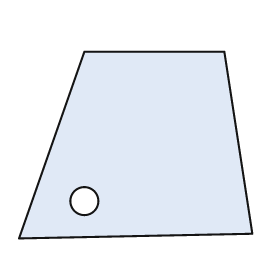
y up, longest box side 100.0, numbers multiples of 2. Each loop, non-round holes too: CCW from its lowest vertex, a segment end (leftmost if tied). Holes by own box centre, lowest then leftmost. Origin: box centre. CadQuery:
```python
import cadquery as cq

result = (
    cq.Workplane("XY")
    .moveTo(-50.0, -40.0)
    .lineTo(50.0, -38.0)
    .lineTo(38.0, 40.0)
    .lineTo(-22.0, 40.0)
    .close()
    .moveTo(-22.0, -24.0)
    .circle(6.0)
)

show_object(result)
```